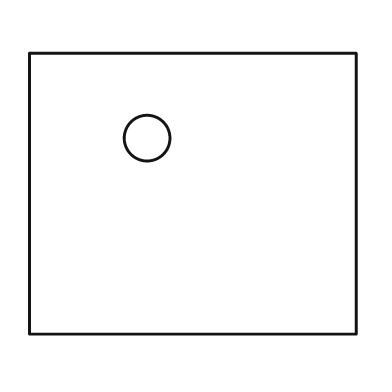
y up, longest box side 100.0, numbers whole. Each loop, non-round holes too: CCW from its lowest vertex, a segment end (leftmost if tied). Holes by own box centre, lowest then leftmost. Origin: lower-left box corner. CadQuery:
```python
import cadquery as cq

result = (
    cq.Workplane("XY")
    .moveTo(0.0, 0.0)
    .lineTo(100.0, 0.0)
    .lineTo(100.0, 86.0)
    .lineTo(0.0, 86.0)
    .close()
    .moveTo(36.0, 60.0)
    .circle(7.0)
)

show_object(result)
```